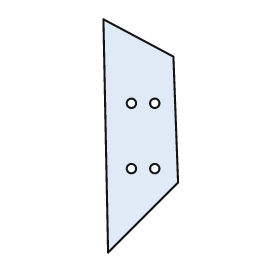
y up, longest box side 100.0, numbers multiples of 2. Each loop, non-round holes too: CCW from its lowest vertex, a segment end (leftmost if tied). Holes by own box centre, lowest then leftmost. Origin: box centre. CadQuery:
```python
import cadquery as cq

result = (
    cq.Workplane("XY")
    .moveTo(-14.0, -50.0)
    .lineTo(16.0, -20.0)
    .lineTo(14.0, 34.0)
    .lineTo(-16.0, 50.0)
    .close()
    .moveTo(-4.0, -14.0)
    .circle(2.0)
    .moveTo(6.0, -14.0)
    .circle(2.0)
    .moveTo(-4.0, 14.0)
    .circle(2.0)
    .moveTo(6.0, 14.0)
    .circle(2.0)
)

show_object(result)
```